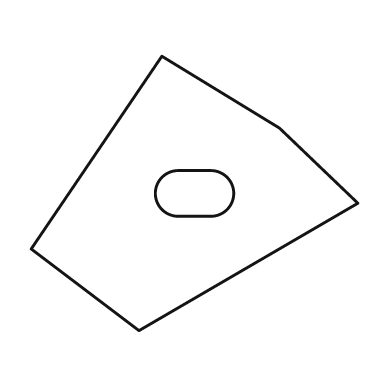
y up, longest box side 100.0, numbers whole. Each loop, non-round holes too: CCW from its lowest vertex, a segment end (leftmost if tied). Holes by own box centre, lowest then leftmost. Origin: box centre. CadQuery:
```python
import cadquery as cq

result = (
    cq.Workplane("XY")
    .moveTo(-17.0, -42.0)
    .lineTo(50.0, -3.0)
    .lineTo(26.0, 20.0)
    .lineTo(-10.0, 42.0)
    .lineTo(-50.0, -17.0)
    .close()
    .moveTo(-5.0, -7.0)
    .lineTo(5.0, -7.0)
    .threePointArc((12.0, 0.0), (5.0, 7.0))
    .lineTo(-5.0, 7.0)
    .threePointArc((-12.0, 0.0), (-5.0, -7.0))
    .close()
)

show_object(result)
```